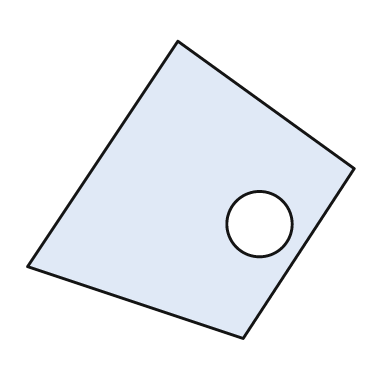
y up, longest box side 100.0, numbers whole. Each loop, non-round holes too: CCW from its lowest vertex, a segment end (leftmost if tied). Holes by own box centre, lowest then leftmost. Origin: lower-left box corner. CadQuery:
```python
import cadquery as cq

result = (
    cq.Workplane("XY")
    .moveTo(66.0, 0.0)
    .lineTo(100.0, 52.0)
    .lineTo(46.0, 91.0)
    .lineTo(0.0, 22.0)
    .close()
    .moveTo(71.0, 35.0)
    .circle(10.0)
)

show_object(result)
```